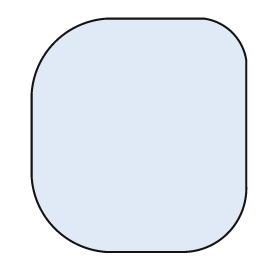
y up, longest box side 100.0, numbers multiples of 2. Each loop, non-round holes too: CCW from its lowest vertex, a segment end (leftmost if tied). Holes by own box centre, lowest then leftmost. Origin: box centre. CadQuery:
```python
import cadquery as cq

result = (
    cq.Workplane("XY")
    .moveTo(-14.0, -50.0)
    .lineTo(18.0, -50.0)
    .threePointArc((38.0, -42.0), (46.0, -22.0))
    .lineTo(46.0, 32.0)
    .threePointArc((40.0, 44.0), (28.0, 50.0))
    .lineTo(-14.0, 50.0)
    .threePointArc((-36.0, 40.0), (-46.0, 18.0))
    .lineTo(-46.0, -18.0)
    .threePointArc((-36.0, -40.0), (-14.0, -50.0))
    .close()
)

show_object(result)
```